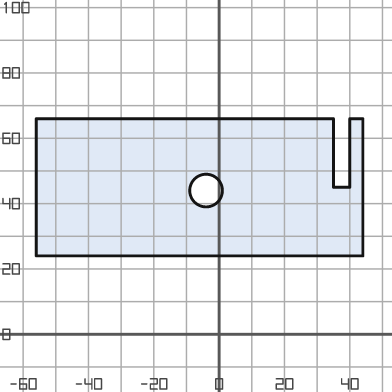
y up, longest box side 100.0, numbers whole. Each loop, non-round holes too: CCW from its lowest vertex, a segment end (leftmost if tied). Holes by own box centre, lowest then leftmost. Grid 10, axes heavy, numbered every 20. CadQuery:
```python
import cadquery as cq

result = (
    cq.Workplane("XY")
    .moveTo(-56.0, 24.0)
    .lineTo(44.0, 24.0)
    .lineTo(44.0, 66.0)
    .lineTo(40.0, 66.0)
    .lineTo(40.0, 45.0)
    .lineTo(35.0, 45.0)
    .lineTo(35.0, 66.0)
    .lineTo(-56.0, 66.0)
    .close()
    .moveTo(-4.0, 44.0)
    .circle(5.0)
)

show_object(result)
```